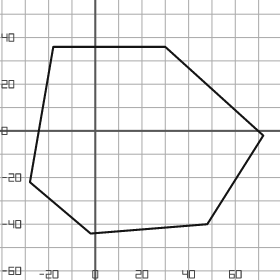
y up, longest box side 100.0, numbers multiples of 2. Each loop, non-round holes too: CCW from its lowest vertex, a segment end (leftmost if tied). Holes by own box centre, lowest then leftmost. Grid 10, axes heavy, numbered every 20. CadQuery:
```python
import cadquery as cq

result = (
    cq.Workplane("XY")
    .moveTo(-2.0, -44.0)
    .lineTo(48.0, -40.0)
    .lineTo(72.0, -2.0)
    .lineTo(30.0, 36.0)
    .lineTo(-18.0, 36.0)
    .lineTo(-28.0, -22.0)
    .close()
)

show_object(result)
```